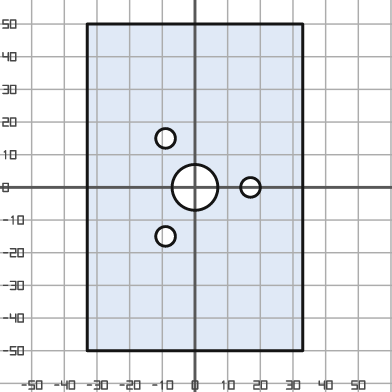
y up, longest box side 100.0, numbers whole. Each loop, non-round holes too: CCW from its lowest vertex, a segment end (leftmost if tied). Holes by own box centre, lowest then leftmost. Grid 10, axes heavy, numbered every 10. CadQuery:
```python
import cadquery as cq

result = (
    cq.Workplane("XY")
    .moveTo(-33.0, -50.0)
    .lineTo(33.0, -50.0)
    .lineTo(33.0, 50.0)
    .lineTo(-33.0, 50.0)
    .close()
    .moveTo(-9.0, -15.0)
    .circle(3.0)
    .moveTo(0.0, 0.0)
    .circle(7.0)
    .moveTo(17.0, 0.0)
    .circle(3.0)
    .moveTo(-9.0, 15.0)
    .circle(3.0)
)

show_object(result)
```